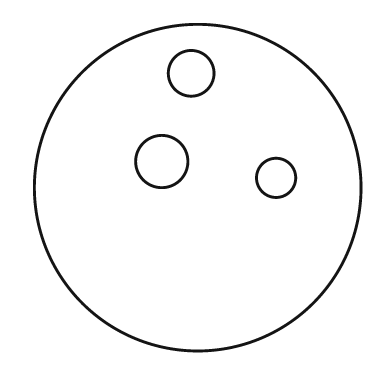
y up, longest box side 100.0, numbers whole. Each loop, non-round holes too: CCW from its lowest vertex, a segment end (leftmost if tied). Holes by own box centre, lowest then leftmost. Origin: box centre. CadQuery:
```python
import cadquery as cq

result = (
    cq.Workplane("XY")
    .moveTo(0.0, 0.0)
    .circle(50.0)
    .moveTo(24.0, 3.0)
    .circle(6.0)
    .moveTo(-11.0, 8.0)
    .circle(8.0)
    .moveTo(-2.0, 35.0)
    .circle(7.0)
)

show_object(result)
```